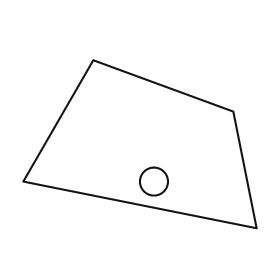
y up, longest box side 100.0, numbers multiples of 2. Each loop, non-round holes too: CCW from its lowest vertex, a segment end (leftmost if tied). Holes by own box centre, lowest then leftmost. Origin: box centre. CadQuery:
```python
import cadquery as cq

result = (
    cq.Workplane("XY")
    .moveTo(50.0, -36.0)
    .lineTo(40.0, 14.0)
    .lineTo(-20.0, 36.0)
    .lineTo(-50.0, -16.0)
    .close()
    .moveTo(6.0, -16.0)
    .circle(6.0)
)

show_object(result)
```